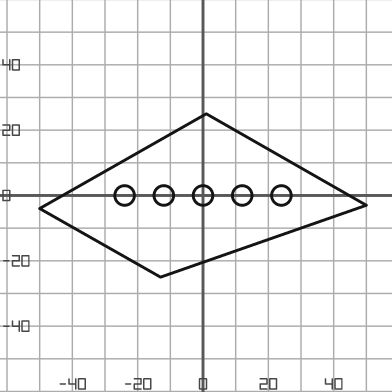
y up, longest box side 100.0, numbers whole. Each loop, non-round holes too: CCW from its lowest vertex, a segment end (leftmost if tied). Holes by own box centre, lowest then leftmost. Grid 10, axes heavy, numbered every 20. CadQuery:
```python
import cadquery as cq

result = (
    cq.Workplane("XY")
    .moveTo(-13.0, -25.0)
    .lineTo(50.0, -3.0)
    .lineTo(1.0, 25.0)
    .lineTo(-50.0, -4.0)
    .close()
    .moveTo(-24.0, 0.0)
    .circle(3.0)
    .moveTo(-12.0, 0.0)
    .circle(3.0)
    .moveTo(0.0, 0.0)
    .circle(3.0)
    .moveTo(12.0, 0.0)
    .circle(3.0)
    .moveTo(24.0, 0.0)
    .circle(3.0)
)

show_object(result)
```